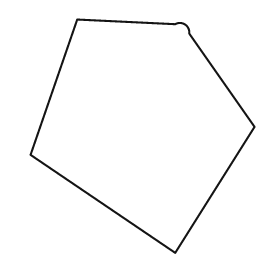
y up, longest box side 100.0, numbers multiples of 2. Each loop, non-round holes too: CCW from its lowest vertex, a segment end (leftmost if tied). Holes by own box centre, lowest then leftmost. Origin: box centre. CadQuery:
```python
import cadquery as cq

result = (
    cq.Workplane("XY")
    .moveTo(14.0, -50.0)
    .lineTo(48.0, 4.0)
    .lineTo(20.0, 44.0)
    .threePointArc((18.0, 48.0), (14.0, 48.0))
    .lineTo(-28.0, 50.0)
    .lineTo(-48.0, -8.0)
    .close()
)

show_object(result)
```